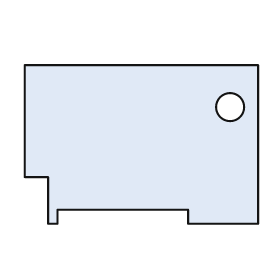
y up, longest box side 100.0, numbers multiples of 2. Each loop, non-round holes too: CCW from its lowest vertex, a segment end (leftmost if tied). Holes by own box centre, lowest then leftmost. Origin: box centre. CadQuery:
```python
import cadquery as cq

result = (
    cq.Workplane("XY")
    .moveTo(-40.0, -34.0)
    .lineTo(-36.0, -34.0)
    .lineTo(-36.0, -28.0)
    .lineTo(20.0, -28.0)
    .lineTo(20.0, -34.0)
    .lineTo(50.0, -34.0)
    .lineTo(50.0, 34.0)
    .lineTo(-50.0, 34.0)
    .lineTo(-50.0, -14.0)
    .lineTo(-40.0, -14.0)
    .close()
    .moveTo(38.0, 16.0)
    .circle(6.0)
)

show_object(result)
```